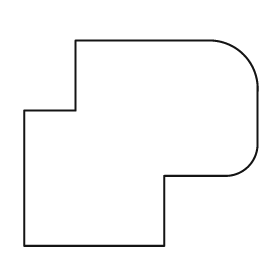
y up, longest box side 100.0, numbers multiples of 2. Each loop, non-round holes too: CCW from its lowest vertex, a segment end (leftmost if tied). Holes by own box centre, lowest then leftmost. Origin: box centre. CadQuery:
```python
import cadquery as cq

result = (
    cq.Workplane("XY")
    .moveTo(-50.0, -44.0)
    .lineTo(10.0, -44.0)
    .lineTo(10.0, -14.0)
    .lineTo(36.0, -14.0)
    .threePointArc((46.0, -10.0), (50.0, 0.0))
    .lineTo(50.0, 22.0)
    .threePointArc((44.0, 38.0), (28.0, 44.0))
    .lineTo(-28.0, 44.0)
    .lineTo(-28.0, 14.0)
    .lineTo(-50.0, 14.0)
    .close()
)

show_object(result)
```